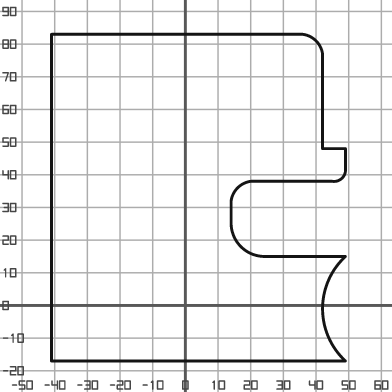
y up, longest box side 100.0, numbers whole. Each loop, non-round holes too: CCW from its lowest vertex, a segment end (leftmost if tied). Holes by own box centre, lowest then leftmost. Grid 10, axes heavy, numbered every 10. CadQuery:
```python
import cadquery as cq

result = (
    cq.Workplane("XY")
    .moveTo(-41.0, -17.0)
    .lineTo(49.0, -17.0)
    .threePointArc((42.0, -1.0), (49.0, 15.0))
    .lineTo(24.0, 15.0)
    .threePointArc((17.0, 18.0), (14.0, 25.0))
    .lineTo(14.0, 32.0)
    .threePointArc((16.0, 36.0), (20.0, 38.0))
    .lineTo(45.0, 38.0)
    .threePointArc((48.0, 39.0), (49.0, 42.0))
    .lineTo(49.0, 48.0)
    .lineTo(42.0, 48.0)
    .lineTo(42.0, 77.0)
    .threePointArc((40.0, 81.0), (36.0, 83.0))
    .lineTo(-41.0, 83.0)
    .close()
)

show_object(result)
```